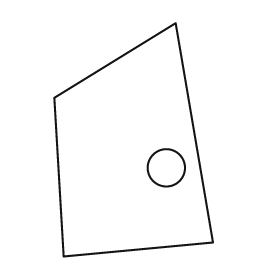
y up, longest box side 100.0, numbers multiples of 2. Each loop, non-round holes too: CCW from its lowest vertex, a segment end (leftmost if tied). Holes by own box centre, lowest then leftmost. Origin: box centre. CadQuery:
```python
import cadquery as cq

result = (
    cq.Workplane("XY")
    .moveTo(-30.0, -50.0)
    .lineTo(34.0, -44.0)
    .lineTo(18.0, 50.0)
    .lineTo(-34.0, 18.0)
    .close()
    .moveTo(14.0, -12.0)
    .circle(8.0)
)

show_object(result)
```